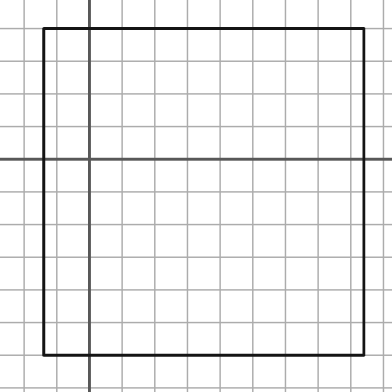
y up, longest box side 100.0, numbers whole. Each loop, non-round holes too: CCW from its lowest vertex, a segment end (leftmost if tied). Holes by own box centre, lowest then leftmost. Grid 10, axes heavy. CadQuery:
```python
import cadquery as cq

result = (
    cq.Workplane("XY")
    .moveTo(-14.0, -60.0)
    .lineTo(84.0, -60.0)
    .lineTo(84.0, 40.0)
    .lineTo(-14.0, 40.0)
    .close()
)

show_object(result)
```